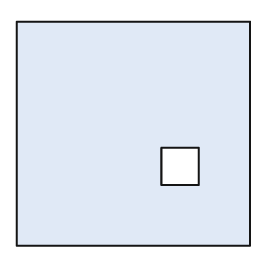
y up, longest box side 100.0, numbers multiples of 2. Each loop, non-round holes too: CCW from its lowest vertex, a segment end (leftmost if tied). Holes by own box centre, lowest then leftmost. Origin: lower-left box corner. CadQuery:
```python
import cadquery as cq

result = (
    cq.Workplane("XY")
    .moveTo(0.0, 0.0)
    .lineTo(100.0, 0.0)
    .lineTo(100.0, 96.0)
    .lineTo(0.0, 96.0)
    .close()
    .moveTo(62.0, 26.0)
    .lineTo(78.0, 26.0)
    .lineTo(78.0, 42.0)
    .lineTo(62.0, 42.0)
    .close()
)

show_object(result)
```